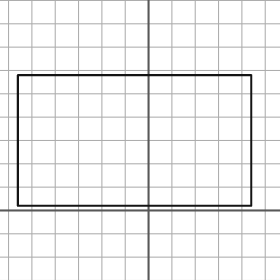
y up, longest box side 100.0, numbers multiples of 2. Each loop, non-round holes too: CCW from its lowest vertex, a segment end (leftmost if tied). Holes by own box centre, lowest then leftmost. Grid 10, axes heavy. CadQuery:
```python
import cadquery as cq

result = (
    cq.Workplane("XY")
    .moveTo(-56.0, 2.0)
    .lineTo(44.0, 2.0)
    .lineTo(44.0, 58.0)
    .lineTo(-56.0, 58.0)
    .close()
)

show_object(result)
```